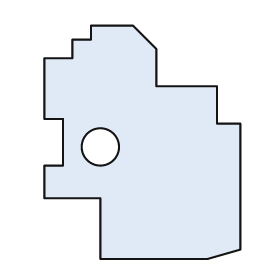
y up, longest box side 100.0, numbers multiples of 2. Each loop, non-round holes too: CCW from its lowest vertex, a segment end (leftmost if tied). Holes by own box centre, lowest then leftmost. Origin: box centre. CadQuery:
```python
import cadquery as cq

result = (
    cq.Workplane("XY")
    .moveTo(-18.0, -50.0)
    .lineTo(28.0, -50.0)
    .lineTo(42.0, -46.0)
    .lineTo(42.0, 8.0)
    .lineTo(32.0, 8.0)
    .lineTo(32.0, 24.0)
    .lineTo(6.0, 24.0)
    .lineTo(6.0, 40.0)
    .lineTo(-4.0, 50.0)
    .lineTo(-22.0, 50.0)
    .lineTo(-22.0, 44.0)
    .lineTo(-30.0, 44.0)
    .lineTo(-30.0, 36.0)
    .lineTo(-42.0, 36.0)
    .lineTo(-42.0, 10.0)
    .lineTo(-34.0, 10.0)
    .lineTo(-34.0, -10.0)
    .lineTo(-42.0, -10.0)
    .lineTo(-42.0, -24.0)
    .lineTo(-18.0, -24.0)
    .close()
    .moveTo(-18.0, -2.0)
    .circle(8.0)
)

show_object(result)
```